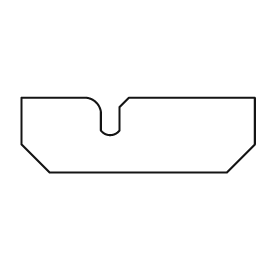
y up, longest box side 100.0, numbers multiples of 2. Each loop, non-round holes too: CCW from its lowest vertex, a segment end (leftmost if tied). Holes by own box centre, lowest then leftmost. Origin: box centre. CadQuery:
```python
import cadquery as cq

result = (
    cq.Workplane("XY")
    .moveTo(-38.0, -16.0)
    .lineTo(38.0, -16.0)
    .lineTo(50.0, -4.0)
    .lineTo(50.0, 16.0)
    .lineTo(-4.0, 16.0)
    .lineTo(-8.0, 12.0)
    .lineTo(-8.0, 2.0)
    .threePointArc((-12.0, 0.0), (-16.0, 2.0))
    .lineTo(-16.0, 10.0)
    .threePointArc((-18.0, 14.0), (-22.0, 16.0))
    .lineTo(-50.0, 16.0)
    .lineTo(-50.0, -4.0)
    .close()
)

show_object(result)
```